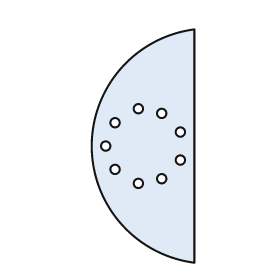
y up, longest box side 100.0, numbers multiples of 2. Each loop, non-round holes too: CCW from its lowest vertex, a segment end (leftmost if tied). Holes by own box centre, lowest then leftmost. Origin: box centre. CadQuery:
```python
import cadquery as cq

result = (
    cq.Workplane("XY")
    .moveTo(22.0, -50.0)
    .lineTo(22.0, 50.0)
    .threePointArc((-22.0, 0.0), (22.0, -50.0))
    .close()
    .moveTo(-2.0, -16.0)
    .circle(2.0)
    .moveTo(8.0, -14.0)
    .circle(2.0)
    .moveTo(-12.0, -10.0)
    .circle(2.0)
    .moveTo(16.0, -6.0)
    .circle(2.0)
    .moveTo(-16.0, 0.0)
    .circle(2.0)
    .moveTo(16.0, 6.0)
    .circle(2.0)
    .moveTo(-12.0, 10.0)
    .circle(2.0)
    .moveTo(8.0, 14.0)
    .circle(2.0)
    .moveTo(-2.0, 16.0)
    .circle(2.0)
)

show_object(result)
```